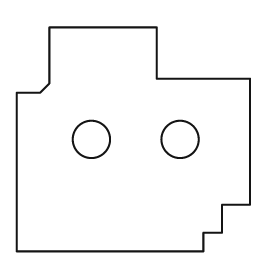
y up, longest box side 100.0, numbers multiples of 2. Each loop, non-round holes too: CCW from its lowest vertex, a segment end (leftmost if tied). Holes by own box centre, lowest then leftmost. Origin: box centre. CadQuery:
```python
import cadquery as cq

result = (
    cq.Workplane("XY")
    .moveTo(-50.0, -48.0)
    .lineTo(30.0, -48.0)
    .lineTo(30.0, -40.0)
    .lineTo(38.0, -40.0)
    .lineTo(38.0, -28.0)
    .lineTo(50.0, -28.0)
    .lineTo(50.0, 26.0)
    .lineTo(10.0, 26.0)
    .lineTo(10.0, 48.0)
    .lineTo(-36.0, 48.0)
    .lineTo(-36.0, 24.0)
    .lineTo(-40.0, 20.0)
    .lineTo(-50.0, 20.0)
    .close()
    .moveTo(-18.0, 0.0)
    .circle(8.0)
    .moveTo(20.0, 0.0)
    .circle(8.0)
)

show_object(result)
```